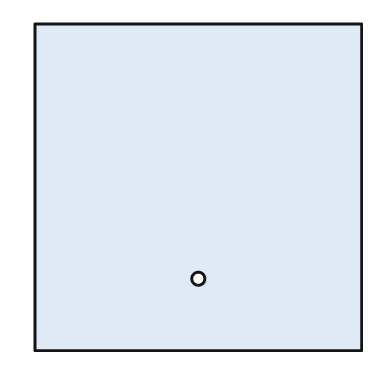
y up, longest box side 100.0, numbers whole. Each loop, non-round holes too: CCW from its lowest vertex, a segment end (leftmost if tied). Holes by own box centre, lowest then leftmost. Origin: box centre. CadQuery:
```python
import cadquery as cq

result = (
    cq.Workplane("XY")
    .moveTo(-50.0, -50.0)
    .lineTo(50.0, -50.0)
    .lineTo(50.0, 50.0)
    .lineTo(-50.0, 50.0)
    .close()
    .moveTo(0.0, -28.0)
    .circle(2.0)
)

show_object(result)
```